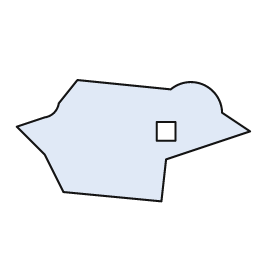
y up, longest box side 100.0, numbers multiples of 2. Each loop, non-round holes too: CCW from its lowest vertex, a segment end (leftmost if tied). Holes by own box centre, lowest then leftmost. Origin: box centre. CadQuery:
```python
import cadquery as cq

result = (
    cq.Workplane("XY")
    .moveTo(12.0, -26.0)
    .lineTo(14.0, -8.0)
    .lineTo(50.0, 4.0)
    .lineTo(38.0, 12.0)
    .threePointArc((30.0, 24.0), (16.0, 22.0))
    .lineTo(-24.0, 26.0)
    .lineTo(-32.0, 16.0)
    .threePointArc((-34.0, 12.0), (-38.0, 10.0))
    .lineTo(-50.0, 6.0)
    .lineTo(-38.0, -6.0)
    .lineTo(-30.0, -22.0)
    .close()
    .moveTo(10.0, 0.0)
    .lineTo(18.0, 0.0)
    .lineTo(18.0, 8.0)
    .lineTo(10.0, 8.0)
    .close()
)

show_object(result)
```